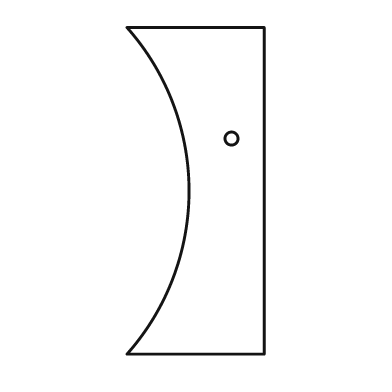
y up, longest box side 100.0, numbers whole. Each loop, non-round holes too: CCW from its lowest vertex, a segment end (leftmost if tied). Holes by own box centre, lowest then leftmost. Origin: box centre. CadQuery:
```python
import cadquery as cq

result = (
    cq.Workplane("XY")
    .moveTo(-21.0, -50.0)
    .lineTo(21.0, -50.0)
    .lineTo(21.0, 50.0)
    .lineTo(-21.0, 50.0)
    .threePointArc((-2.0, 0.0), (-21.0, -50.0))
    .close()
    .moveTo(11.0, 16.0)
    .circle(2.0)
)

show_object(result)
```